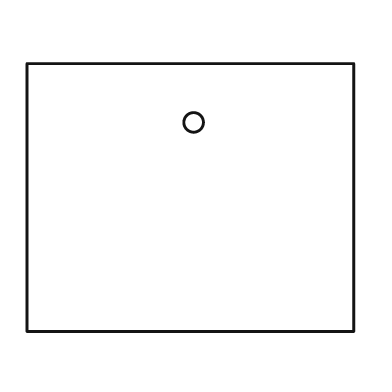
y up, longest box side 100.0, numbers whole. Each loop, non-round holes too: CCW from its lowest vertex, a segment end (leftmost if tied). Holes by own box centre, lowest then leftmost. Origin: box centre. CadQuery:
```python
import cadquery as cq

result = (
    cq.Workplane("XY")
    .moveTo(-50.0, -41.0)
    .lineTo(50.0, -41.0)
    .lineTo(50.0, 41.0)
    .lineTo(-50.0, 41.0)
    .close()
    .moveTo(1.0, 23.0)
    .circle(3.0)
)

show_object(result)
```